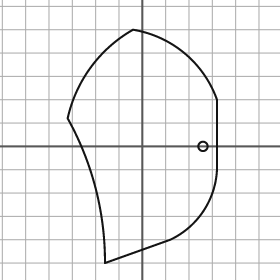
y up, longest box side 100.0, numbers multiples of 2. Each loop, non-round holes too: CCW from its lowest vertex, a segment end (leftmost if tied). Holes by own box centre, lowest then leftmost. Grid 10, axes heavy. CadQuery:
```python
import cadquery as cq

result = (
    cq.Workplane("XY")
    .moveTo(-16.0, -50.0)
    .lineTo(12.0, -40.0)
    .threePointArc((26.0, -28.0), (32.0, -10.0))
    .lineTo(32.0, 20.0)
    .threePointArc((18.0, 40.0), (-4.0, 50.0))
    .threePointArc((-22.0, 34.0), (-32.0, 12.0))
    .threePointArc((-20.0, -18.0), (-16.0, -50.0))
    .close()
    .moveTo(26.0, 0.0)
    .circle(2.0)
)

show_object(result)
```